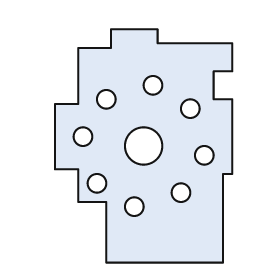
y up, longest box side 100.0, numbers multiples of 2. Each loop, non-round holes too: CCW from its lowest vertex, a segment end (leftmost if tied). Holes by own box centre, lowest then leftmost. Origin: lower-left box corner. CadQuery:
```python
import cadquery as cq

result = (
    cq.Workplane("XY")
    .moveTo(22.0, 0.0)
    .lineTo(72.0, 0.0)
    .lineTo(72.0, 38.0)
    .lineTo(76.0, 38.0)
    .lineTo(76.0, 70.0)
    .lineTo(68.0, 70.0)
    .lineTo(68.0, 82.0)
    .lineTo(76.0, 82.0)
    .lineTo(76.0, 94.0)
    .lineTo(44.0, 94.0)
    .lineTo(44.0, 100.0)
    .lineTo(24.0, 100.0)
    .lineTo(24.0, 92.0)
    .lineTo(10.0, 92.0)
    .lineTo(10.0, 68.0)
    .lineTo(0.0, 68.0)
    .lineTo(0.0, 40.0)
    .lineTo(10.0, 40.0)
    .lineTo(10.0, 26.0)
    .lineTo(22.0, 26.0)
    .close()
    .moveTo(34.0, 24.0)
    .circle(4.0)
    .moveTo(54.0, 30.0)
    .circle(4.0)
    .moveTo(18.0, 34.0)
    .circle(4.0)
    .moveTo(64.0, 46.0)
    .circle(4.0)
    .moveTo(38.0, 50.0)
    .circle(8.0)
    .moveTo(12.0, 54.0)
    .circle(4.0)
    .moveTo(58.0, 66.0)
    .circle(4.0)
    .moveTo(22.0, 70.0)
    .circle(4.0)
    .moveTo(42.0, 76.0)
    .circle(4.0)
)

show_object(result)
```